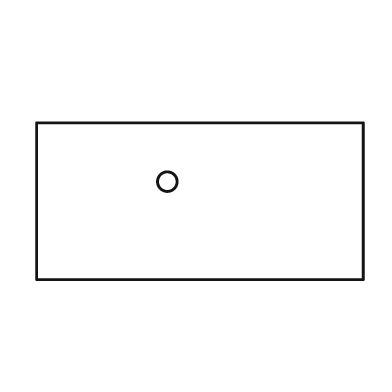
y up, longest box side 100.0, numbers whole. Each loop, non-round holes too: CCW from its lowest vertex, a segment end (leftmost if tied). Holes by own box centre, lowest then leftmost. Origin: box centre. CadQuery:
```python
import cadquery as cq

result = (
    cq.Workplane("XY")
    .moveTo(-50.0, -24.0)
    .lineTo(50.0, -24.0)
    .lineTo(50.0, 24.0)
    .lineTo(-50.0, 24.0)
    .close()
    .moveTo(-10.0, 6.0)
    .circle(3.0)
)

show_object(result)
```